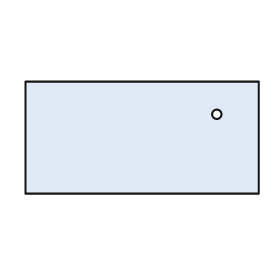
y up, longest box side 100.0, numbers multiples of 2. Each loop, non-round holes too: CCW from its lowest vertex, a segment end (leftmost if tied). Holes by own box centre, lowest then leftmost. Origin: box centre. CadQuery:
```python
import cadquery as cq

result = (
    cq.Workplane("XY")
    .moveTo(-50.0, -24.0)
    .lineTo(50.0, -24.0)
    .lineTo(50.0, 24.0)
    .lineTo(-50.0, 24.0)
    .close()
    .moveTo(32.0, 10.0)
    .circle(2.0)
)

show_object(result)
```